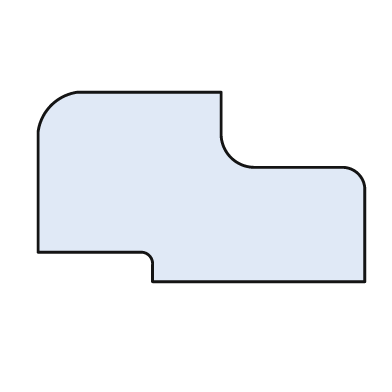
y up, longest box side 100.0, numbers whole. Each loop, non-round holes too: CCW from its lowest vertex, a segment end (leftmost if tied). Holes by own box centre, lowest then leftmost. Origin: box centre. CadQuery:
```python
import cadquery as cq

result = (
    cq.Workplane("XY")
    .moveTo(-15.0, -29.0)
    .lineTo(50.0, -29.0)
    .lineTo(50.0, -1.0)
    .threePointArc((48.0, 4.0), (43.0, 6.0))
    .lineTo(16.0, 6.0)
    .threePointArc((9.0, 9.0), (6.0, 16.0))
    .lineTo(6.0, 29.0)
    .lineTo(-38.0, 29.0)
    .threePointArc((-46.0, 25.0), (-50.0, 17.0))
    .lineTo(-50.0, -20.0)
    .lineTo(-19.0, -20.0)
    .threePointArc((-16.0, -21.0), (-15.0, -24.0))
    .close()
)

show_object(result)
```